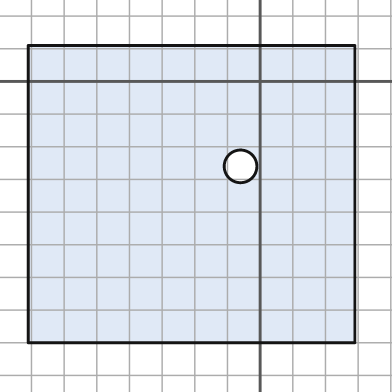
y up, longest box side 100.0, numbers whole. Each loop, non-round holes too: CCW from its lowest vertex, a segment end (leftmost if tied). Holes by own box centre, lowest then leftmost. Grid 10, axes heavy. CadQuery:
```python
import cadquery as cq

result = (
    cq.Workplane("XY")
    .moveTo(-71.0, -80.0)
    .lineTo(29.0, -80.0)
    .lineTo(29.0, 11.0)
    .lineTo(-71.0, 11.0)
    .close()
    .moveTo(-6.0, -26.0)
    .circle(5.0)
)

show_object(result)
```